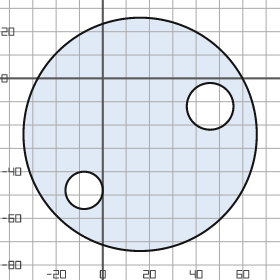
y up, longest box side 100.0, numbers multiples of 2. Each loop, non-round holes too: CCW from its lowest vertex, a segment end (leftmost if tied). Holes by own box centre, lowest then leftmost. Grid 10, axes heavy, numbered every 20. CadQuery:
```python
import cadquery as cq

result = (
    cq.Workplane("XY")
    .moveTo(16.0, -24.0)
    .circle(50.0)
    .moveTo(-8.0, -48.0)
    .circle(8.0)
    .moveTo(46.0, -12.0)
    .circle(10.0)
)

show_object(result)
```